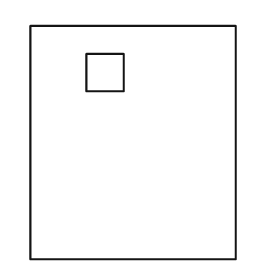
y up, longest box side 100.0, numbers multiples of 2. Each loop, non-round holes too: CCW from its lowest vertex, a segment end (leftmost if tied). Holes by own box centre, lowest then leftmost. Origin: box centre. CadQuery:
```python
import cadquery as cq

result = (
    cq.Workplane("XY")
    .moveTo(-44.0, -50.0)
    .lineTo(44.0, -50.0)
    .lineTo(44.0, 50.0)
    .lineTo(-44.0, 50.0)
    .close()
    .moveTo(-20.0, 22.0)
    .lineTo(-4.0, 22.0)
    .lineTo(-4.0, 38.0)
    .lineTo(-20.0, 38.0)
    .close()
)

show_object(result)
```